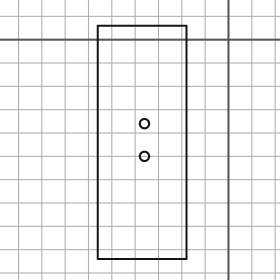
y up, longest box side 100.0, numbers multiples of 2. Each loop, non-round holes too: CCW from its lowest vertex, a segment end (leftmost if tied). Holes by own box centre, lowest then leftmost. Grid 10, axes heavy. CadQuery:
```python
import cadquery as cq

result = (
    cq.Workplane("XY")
    .moveTo(-56.0, -94.0)
    .lineTo(-18.0, -94.0)
    .lineTo(-18.0, 6.0)
    .lineTo(-56.0, 6.0)
    .close()
    .moveTo(-36.0, -50.0)
    .circle(2.0)
    .moveTo(-36.0, -36.0)
    .circle(2.0)
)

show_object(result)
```